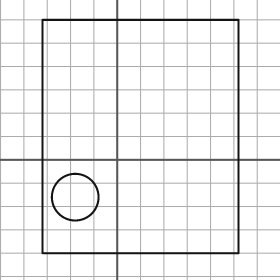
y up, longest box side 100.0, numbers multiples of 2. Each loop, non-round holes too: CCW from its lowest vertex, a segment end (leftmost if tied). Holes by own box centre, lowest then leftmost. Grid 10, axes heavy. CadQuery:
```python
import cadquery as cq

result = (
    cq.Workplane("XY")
    .moveTo(-32.0, -40.0)
    .lineTo(52.0, -40.0)
    .lineTo(52.0, 60.0)
    .lineTo(-32.0, 60.0)
    .close()
    .moveTo(-18.0, -16.0)
    .circle(10.0)
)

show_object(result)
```